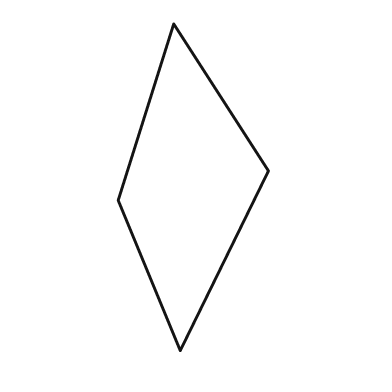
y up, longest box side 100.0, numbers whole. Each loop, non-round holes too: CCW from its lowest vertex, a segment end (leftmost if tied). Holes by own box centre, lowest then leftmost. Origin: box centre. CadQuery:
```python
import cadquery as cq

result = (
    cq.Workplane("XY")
    .moveTo(-4.0, -50.0)
    .lineTo(23.0, 5.0)
    .lineTo(-6.0, 50.0)
    .lineTo(-23.0, -4.0)
    .close()
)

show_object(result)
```